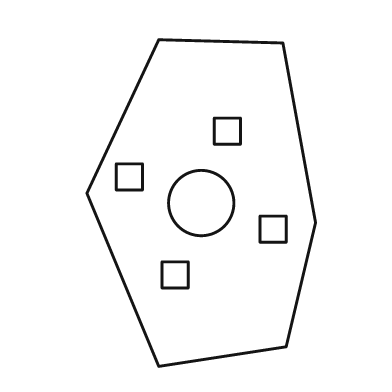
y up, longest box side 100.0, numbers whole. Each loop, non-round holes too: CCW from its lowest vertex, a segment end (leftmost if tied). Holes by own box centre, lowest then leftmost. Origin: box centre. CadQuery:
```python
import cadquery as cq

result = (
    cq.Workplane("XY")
    .moveTo(-13.0, -50.0)
    .lineTo(26.0, -44.0)
    .lineTo(35.0, -6.0)
    .lineTo(25.0, 49.0)
    .lineTo(-13.0, 50.0)
    .lineTo(-35.0, 3.0)
    .close()
    .moveTo(-12.0, -26.0)
    .lineTo(-4.0, -26.0)
    .lineTo(-4.0, -18.0)
    .lineTo(-12.0, -18.0)
    .close()
    .moveTo(18.0, -12.0)
    .lineTo(26.0, -12.0)
    .lineTo(26.0, -4.0)
    .lineTo(18.0, -4.0)
    .close()
    .moveTo(0.0, 0.0)
    .circle(10.0)
    .moveTo(-26.0, 4.0)
    .lineTo(-18.0, 4.0)
    .lineTo(-18.0, 12.0)
    .lineTo(-26.0, 12.0)
    .close()
    .moveTo(4.0, 18.0)
    .lineTo(12.0, 18.0)
    .lineTo(12.0, 26.0)
    .lineTo(4.0, 26.0)
    .close()
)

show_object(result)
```